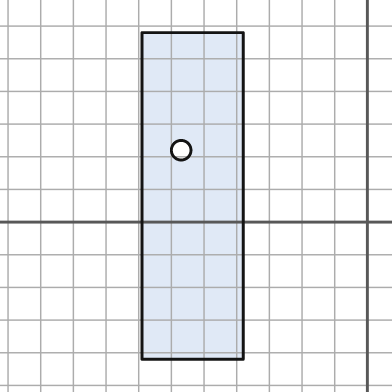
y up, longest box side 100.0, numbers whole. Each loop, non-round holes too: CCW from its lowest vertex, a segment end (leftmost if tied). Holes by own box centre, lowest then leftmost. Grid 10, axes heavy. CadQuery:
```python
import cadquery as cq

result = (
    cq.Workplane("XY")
    .moveTo(-69.0, -42.0)
    .lineTo(-38.0, -42.0)
    .lineTo(-38.0, 58.0)
    .lineTo(-69.0, 58.0)
    .close()
    .moveTo(-57.0, 22.0)
    .circle(3.0)
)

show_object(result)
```